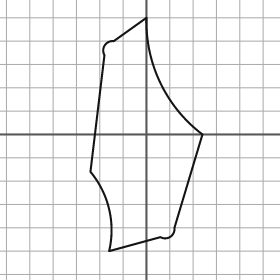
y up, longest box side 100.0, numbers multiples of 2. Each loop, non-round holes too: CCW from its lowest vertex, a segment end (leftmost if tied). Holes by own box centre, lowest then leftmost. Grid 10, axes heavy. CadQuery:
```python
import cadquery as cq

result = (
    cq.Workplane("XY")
    .moveTo(-16.0, -50.0)
    .lineTo(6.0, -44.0)
    .threePointArc((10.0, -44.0), (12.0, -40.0))
    .lineTo(24.0, 0.0)
    .threePointArc((6.0, 22.0), (0.0, 50.0))
    .lineTo(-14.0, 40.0)
    .threePointArc((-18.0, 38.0), (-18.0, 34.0))
    .lineTo(-24.0, -16.0)
    .threePointArc((-16.0, -32.0), (-16.0, -50.0))
    .close()
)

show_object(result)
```